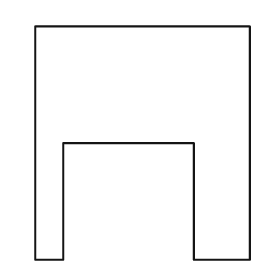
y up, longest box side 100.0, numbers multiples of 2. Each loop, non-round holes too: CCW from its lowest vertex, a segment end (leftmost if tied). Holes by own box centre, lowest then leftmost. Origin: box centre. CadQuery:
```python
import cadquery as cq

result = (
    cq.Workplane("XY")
    .moveTo(-46.0, -50.0)
    .lineTo(-34.0, -50.0)
    .lineTo(-34.0, 0.0)
    .lineTo(22.0, 0.0)
    .lineTo(22.0, -50.0)
    .lineTo(46.0, -50.0)
    .lineTo(46.0, 50.0)
    .lineTo(-46.0, 50.0)
    .close()
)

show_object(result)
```